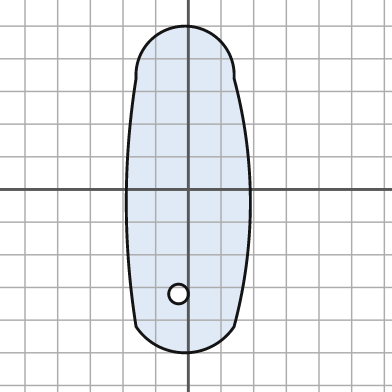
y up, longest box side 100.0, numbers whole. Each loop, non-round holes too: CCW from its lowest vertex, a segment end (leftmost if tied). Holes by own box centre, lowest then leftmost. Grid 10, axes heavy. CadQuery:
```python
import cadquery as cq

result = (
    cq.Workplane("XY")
    .moveTo(-16.0, -42.0)
    .threePointArc((-1.0, -50.0), (14.0, -42.0))
    .threePointArc((19.0, -4.0), (14.0, 34.0))
    .threePointArc((-1.0, 50.0), (-16.0, 34.0))
    .threePointArc((-19.0, -4.0), (-16.0, -42.0))
    .close()
    .moveTo(-3.0, -32.0)
    .circle(3.0)
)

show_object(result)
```